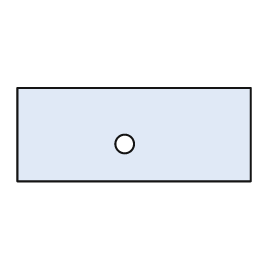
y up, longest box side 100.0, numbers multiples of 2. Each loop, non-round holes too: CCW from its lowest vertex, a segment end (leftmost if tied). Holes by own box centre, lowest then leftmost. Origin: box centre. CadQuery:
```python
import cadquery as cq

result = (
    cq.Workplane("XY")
    .moveTo(-50.0, -20.0)
    .lineTo(50.0, -20.0)
    .lineTo(50.0, 20.0)
    .lineTo(-50.0, 20.0)
    .close()
    .moveTo(-4.0, -4.0)
    .circle(4.0)
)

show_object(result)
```